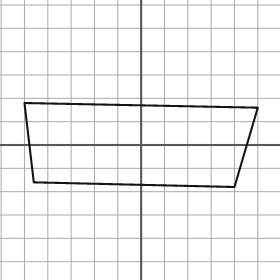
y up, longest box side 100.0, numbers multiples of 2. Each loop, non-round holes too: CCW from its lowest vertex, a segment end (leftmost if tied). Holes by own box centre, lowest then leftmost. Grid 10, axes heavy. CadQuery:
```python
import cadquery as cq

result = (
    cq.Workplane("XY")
    .moveTo(40.0, -18.0)
    .lineTo(50.0, 16.0)
    .lineTo(-50.0, 18.0)
    .lineTo(-46.0, -16.0)
    .close()
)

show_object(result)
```